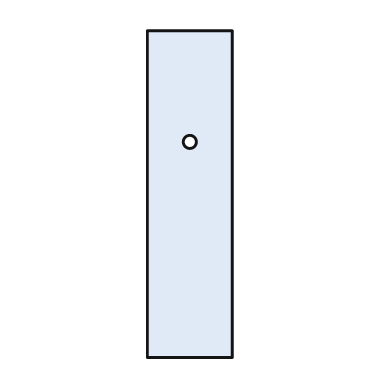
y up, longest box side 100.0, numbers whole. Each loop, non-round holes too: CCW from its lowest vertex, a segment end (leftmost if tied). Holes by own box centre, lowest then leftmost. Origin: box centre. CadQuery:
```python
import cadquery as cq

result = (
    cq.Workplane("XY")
    .moveTo(-13.0, -50.0)
    .lineTo(13.0, -50.0)
    .lineTo(13.0, 50.0)
    .lineTo(-13.0, 50.0)
    .close()
    .moveTo(0.0, 16.0)
    .circle(2.0)
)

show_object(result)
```